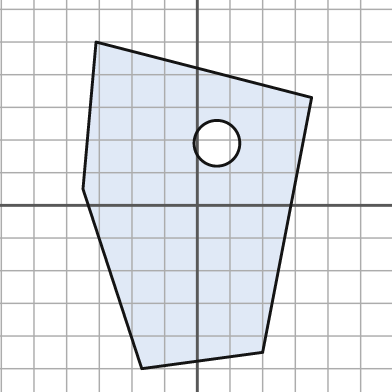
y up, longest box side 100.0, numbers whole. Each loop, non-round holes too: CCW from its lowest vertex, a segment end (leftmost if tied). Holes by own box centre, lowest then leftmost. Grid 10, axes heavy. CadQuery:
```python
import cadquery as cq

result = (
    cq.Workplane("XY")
    .moveTo(-17.0, -50.0)
    .lineTo(20.0, -45.0)
    .lineTo(35.0, 33.0)
    .lineTo(-31.0, 50.0)
    .lineTo(-35.0, 5.0)
    .close()
    .moveTo(6.0, 19.0)
    .circle(7.0)
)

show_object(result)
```